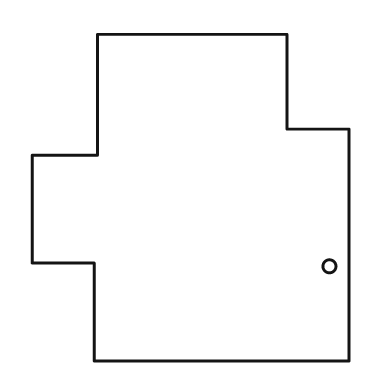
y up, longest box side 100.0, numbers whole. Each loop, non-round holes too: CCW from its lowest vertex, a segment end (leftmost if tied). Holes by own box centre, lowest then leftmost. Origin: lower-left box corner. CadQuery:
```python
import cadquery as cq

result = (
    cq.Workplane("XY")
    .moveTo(19.0, 0.0)
    .lineTo(97.0, 0.0)
    .lineTo(97.0, 71.0)
    .lineTo(78.0, 71.0)
    .lineTo(78.0, 100.0)
    .lineTo(20.0, 100.0)
    .lineTo(20.0, 63.0)
    .lineTo(0.0, 63.0)
    .lineTo(0.0, 30.0)
    .lineTo(19.0, 30.0)
    .close()
    .moveTo(91.0, 29.0)
    .circle(2.0)
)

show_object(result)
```